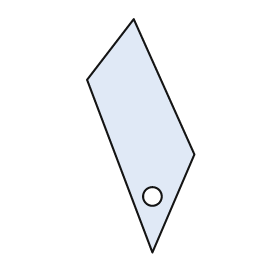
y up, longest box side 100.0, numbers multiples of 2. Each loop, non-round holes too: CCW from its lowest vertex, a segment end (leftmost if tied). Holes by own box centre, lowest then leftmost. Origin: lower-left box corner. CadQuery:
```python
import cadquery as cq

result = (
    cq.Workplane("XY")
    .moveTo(28.0, 0.0)
    .lineTo(46.0, 42.0)
    .lineTo(20.0, 100.0)
    .lineTo(0.0, 74.0)
    .close()
    .moveTo(28.0, 24.0)
    .circle(4.0)
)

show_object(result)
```